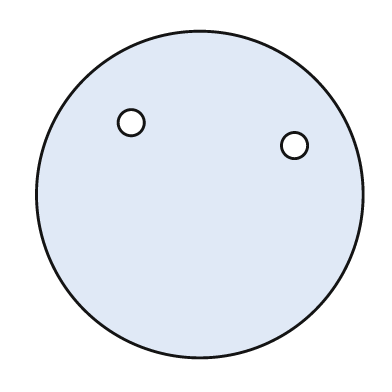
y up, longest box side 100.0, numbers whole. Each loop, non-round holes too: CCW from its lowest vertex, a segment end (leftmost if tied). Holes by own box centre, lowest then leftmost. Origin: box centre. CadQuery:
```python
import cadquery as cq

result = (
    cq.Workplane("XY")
    .moveTo(0.0, 0.0)
    .circle(50.0)
    .moveTo(29.0, 15.0)
    .circle(4.0)
    .moveTo(-21.0, 22.0)
    .circle(4.0)
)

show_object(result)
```